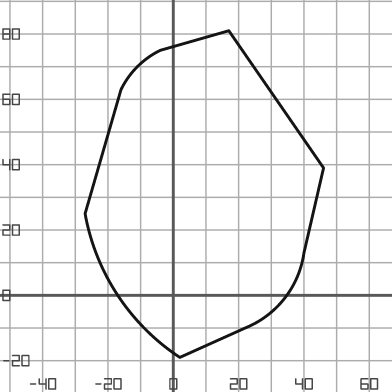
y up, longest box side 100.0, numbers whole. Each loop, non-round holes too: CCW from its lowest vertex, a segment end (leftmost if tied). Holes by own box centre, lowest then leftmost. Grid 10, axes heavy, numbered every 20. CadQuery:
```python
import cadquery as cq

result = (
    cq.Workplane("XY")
    .moveTo(2.0, -19.0)
    .lineTo(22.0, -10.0)
    .threePointArc((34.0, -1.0), (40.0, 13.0))
    .lineTo(46.0, 39.0)
    .lineTo(17.0, 81.0)
    .lineTo(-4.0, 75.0)
    .threePointArc((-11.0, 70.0), (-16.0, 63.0))
    .lineTo(-27.0, 25.0)
    .threePointArc((-17.0, 0.0), (2.0, -19.0))
    .close()
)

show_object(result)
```